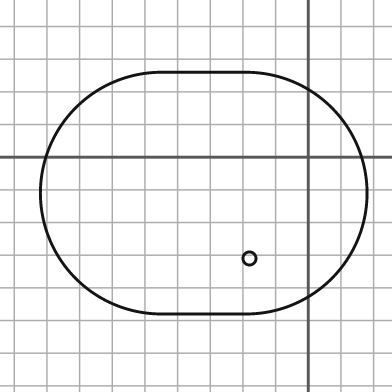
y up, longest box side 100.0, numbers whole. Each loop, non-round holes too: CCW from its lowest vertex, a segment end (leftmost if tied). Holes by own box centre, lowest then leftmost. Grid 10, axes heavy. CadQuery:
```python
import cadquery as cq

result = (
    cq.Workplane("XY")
    .moveTo(-45.0, -48.0)
    .lineTo(-19.0, -48.0)
    .threePointArc((18.0, -11.0), (-19.0, 26.0))
    .lineTo(-45.0, 26.0)
    .threePointArc((-82.0, -11.0), (-45.0, -48.0))
    .close()
    .moveTo(-18.0, -31.0)
    .circle(2.0)
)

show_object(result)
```